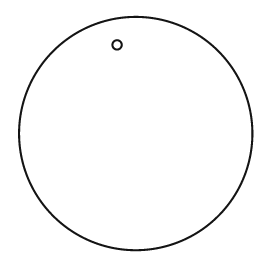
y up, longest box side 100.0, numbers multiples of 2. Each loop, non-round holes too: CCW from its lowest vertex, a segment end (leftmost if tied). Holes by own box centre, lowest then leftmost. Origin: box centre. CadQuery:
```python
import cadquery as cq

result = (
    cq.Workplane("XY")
    .moveTo(0.0, 0.0)
    .circle(50.0)
    .moveTo(-8.0, 38.0)
    .circle(2.0)
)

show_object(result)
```